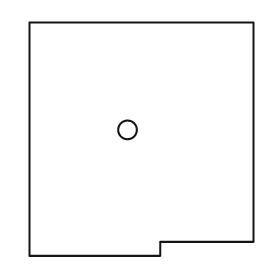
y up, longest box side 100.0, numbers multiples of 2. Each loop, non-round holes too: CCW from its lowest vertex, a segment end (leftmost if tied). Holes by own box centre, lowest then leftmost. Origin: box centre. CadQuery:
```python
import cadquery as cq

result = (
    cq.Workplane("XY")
    .moveTo(-48.0, -50.0)
    .lineTo(8.0, -50.0)
    .lineTo(8.0, -44.0)
    .lineTo(48.0, -44.0)
    .lineTo(48.0, 50.0)
    .lineTo(-48.0, 50.0)
    .close()
    .moveTo(-6.0, 4.0)
    .circle(4.0)
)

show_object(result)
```